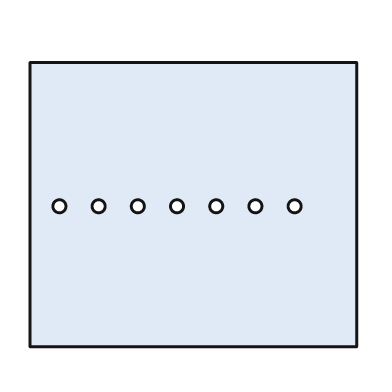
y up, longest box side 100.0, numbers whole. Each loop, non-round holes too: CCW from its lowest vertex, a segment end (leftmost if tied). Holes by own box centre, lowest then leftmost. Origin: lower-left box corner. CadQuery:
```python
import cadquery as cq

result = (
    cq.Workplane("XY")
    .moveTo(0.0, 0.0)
    .lineTo(100.0, 0.0)
    .lineTo(100.0, 87.0)
    .lineTo(0.0, 87.0)
    .close()
    .moveTo(9.0, 43.0)
    .circle(2.0)
    .moveTo(21.0, 43.0)
    .circle(2.0)
    .moveTo(33.0, 43.0)
    .circle(2.0)
    .moveTo(45.0, 43.0)
    .circle(2.0)
    .moveTo(57.0, 43.0)
    .circle(2.0)
    .moveTo(69.0, 43.0)
    .circle(2.0)
    .moveTo(81.0, 43.0)
    .circle(2.0)
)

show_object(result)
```